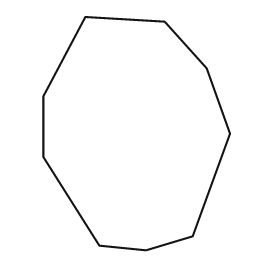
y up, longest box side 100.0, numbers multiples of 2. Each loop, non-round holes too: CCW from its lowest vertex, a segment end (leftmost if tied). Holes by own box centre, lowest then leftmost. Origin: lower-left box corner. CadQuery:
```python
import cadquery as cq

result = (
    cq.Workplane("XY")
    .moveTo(44.0, 0.0)
    .lineTo(64.0, 6.0)
    .lineTo(80.0, 50.0)
    .lineTo(70.0, 78.0)
    .lineTo(52.0, 98.0)
    .lineTo(18.0, 100.0)
    .lineTo(0.0, 66.0)
    .lineTo(0.0, 40.0)
    .lineTo(24.0, 2.0)
    .close()
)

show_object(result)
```